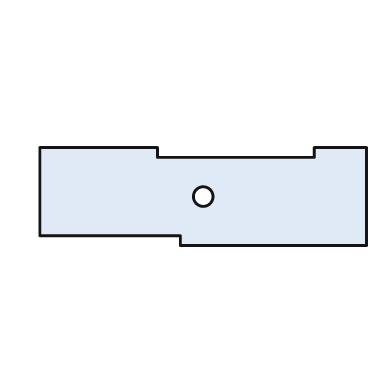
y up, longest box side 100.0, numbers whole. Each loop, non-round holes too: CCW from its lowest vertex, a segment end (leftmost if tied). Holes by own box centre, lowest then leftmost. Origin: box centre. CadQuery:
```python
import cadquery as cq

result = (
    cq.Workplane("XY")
    .moveTo(-7.0, -15.0)
    .lineTo(50.0, -15.0)
    .lineTo(50.0, 15.0)
    .lineTo(34.0, 15.0)
    .lineTo(34.0, 12.0)
    .lineTo(-14.0, 12.0)
    .lineTo(-14.0, 15.0)
    .lineTo(-50.0, 15.0)
    .lineTo(-50.0, -12.0)
    .lineTo(-7.0, -12.0)
    .close()
    .moveTo(0.0, 0.0)
    .circle(3.0)
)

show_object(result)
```